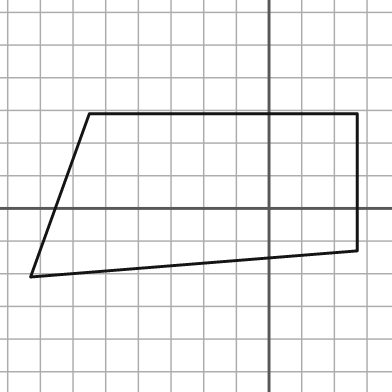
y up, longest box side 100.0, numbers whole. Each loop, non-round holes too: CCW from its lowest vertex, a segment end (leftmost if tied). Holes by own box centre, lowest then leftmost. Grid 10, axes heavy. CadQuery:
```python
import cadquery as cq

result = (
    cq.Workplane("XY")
    .moveTo(-73.0, -21.0)
    .lineTo(27.0, -13.0)
    .lineTo(27.0, 29.0)
    .lineTo(-55.0, 29.0)
    .close()
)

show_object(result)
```